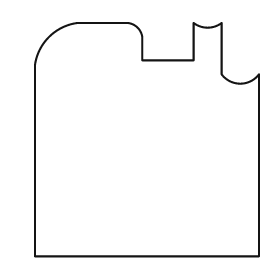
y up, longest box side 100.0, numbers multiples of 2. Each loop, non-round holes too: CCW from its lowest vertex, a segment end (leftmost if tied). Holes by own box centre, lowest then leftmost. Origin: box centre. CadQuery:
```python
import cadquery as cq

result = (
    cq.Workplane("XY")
    .moveTo(-48.0, -50.0)
    .lineTo(48.0, -50.0)
    .lineTo(48.0, 28.0)
    .threePointArc((40.0, 24.0), (32.0, 28.0))
    .lineTo(32.0, 50.0)
    .threePointArc((26.0, 48.0), (20.0, 50.0))
    .lineTo(20.0, 34.0)
    .lineTo(-2.0, 34.0)
    .lineTo(-2.0, 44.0)
    .threePointArc((-4.0, 48.0), (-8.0, 50.0))
    .lineTo(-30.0, 50.0)
    .threePointArc((-42.0, 44.0), (-48.0, 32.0))
    .close()
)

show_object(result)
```